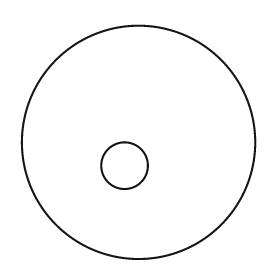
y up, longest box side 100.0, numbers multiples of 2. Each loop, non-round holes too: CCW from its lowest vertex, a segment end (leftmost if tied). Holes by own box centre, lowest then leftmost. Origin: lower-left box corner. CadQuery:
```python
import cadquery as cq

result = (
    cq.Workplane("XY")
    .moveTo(50.0, 50.0)
    .circle(50.0)
    .moveTo(44.0, 40.0)
    .circle(10.0)
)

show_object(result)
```